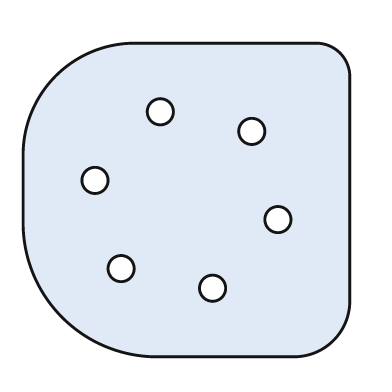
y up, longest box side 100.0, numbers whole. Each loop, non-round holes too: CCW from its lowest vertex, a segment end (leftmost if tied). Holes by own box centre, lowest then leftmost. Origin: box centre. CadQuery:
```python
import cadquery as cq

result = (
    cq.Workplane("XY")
    .moveTo(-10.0, -48.0)
    .lineTo(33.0, -48.0)
    .threePointArc((45.0, -43.0), (50.0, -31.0))
    .lineTo(50.0, 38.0)
    .threePointArc((47.0, 45.0), (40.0, 48.0))
    .lineTo(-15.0, 48.0)
    .threePointArc((-40.0, 38.0), (-50.0, 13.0))
    .lineTo(-50.0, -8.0)
    .threePointArc((-38.0, -36.0), (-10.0, -48.0))
    .close()
    .moveTo(8.0, -27.0)
    .circle(4.0)
    .moveTo(-20.0, -21.0)
    .circle(4.0)
    .moveTo(28.0, -6.0)
    .circle(4.0)
    .moveTo(-28.0, 6.0)
    .circle(4.0)
    .moveTo(20.0, 21.0)
    .circle(4.0)
    .moveTo(-8.0, 27.0)
    .circle(4.0)
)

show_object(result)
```